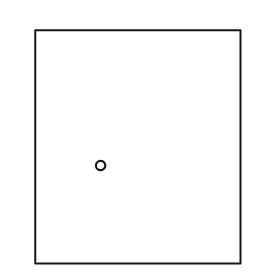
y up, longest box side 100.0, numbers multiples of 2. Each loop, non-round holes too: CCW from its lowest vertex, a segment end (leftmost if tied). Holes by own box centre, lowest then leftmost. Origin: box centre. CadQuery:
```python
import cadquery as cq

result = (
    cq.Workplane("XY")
    .moveTo(-44.0, -50.0)
    .lineTo(44.0, -50.0)
    .lineTo(44.0, 50.0)
    .lineTo(-44.0, 50.0)
    .close()
    .moveTo(-16.0, -8.0)
    .circle(2.0)
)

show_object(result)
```